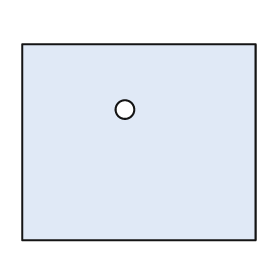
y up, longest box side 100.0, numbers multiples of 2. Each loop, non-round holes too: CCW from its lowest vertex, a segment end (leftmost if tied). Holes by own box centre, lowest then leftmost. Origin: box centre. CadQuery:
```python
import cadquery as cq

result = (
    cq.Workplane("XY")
    .moveTo(-50.0, -42.0)
    .lineTo(50.0, -42.0)
    .lineTo(50.0, 42.0)
    .lineTo(-50.0, 42.0)
    .close()
    .moveTo(-6.0, 14.0)
    .circle(4.0)
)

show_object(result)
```